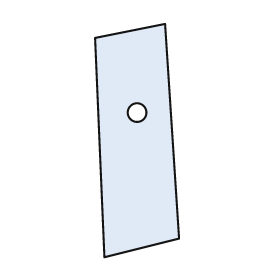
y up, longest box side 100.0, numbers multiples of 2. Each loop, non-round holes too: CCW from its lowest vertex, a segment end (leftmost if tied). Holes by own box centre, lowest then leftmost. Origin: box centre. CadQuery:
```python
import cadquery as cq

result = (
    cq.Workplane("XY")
    .moveTo(-14.0, -50.0)
    .lineTo(18.0, -42.0)
    .lineTo(12.0, 50.0)
    .lineTo(-18.0, 44.0)
    .close()
    .moveTo(0.0, 12.0)
    .circle(4.0)
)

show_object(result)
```